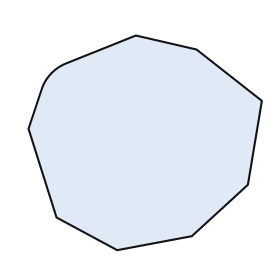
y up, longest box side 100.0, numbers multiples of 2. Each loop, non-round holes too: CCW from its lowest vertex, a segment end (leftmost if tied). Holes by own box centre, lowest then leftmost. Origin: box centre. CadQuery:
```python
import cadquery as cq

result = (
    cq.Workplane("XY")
    .moveTo(-12.0, -46.0)
    .lineTo(20.0, -40.0)
    .lineTo(44.0, -18.0)
    .lineTo(50.0, 18.0)
    .lineTo(22.0, 40.0)
    .lineTo(-4.0, 46.0)
    .lineTo(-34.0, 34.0)
    .threePointArc((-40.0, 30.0), (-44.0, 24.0))
    .lineTo(-50.0, 6.0)
    .lineTo(-38.0, -32.0)
    .close()
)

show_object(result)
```